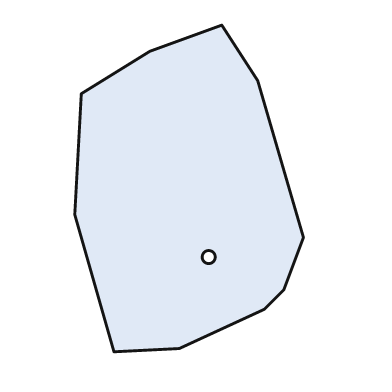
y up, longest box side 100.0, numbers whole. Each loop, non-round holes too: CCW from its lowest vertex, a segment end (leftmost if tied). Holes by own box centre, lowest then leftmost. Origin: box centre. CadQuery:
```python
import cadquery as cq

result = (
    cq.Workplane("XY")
    .moveTo(-23.0, -50.0)
    .lineTo(-3.0, -49.0)
    .lineTo(23.0, -37.0)
    .lineTo(29.0, -31.0)
    .lineTo(35.0, -15.0)
    .lineTo(21.0, 33.0)
    .lineTo(10.0, 50.0)
    .lineTo(-12.0, 42.0)
    .lineTo(-33.0, 29.0)
    .lineTo(-35.0, -8.0)
    .close()
    .moveTo(6.0, -21.0)
    .circle(2.0)
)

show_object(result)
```